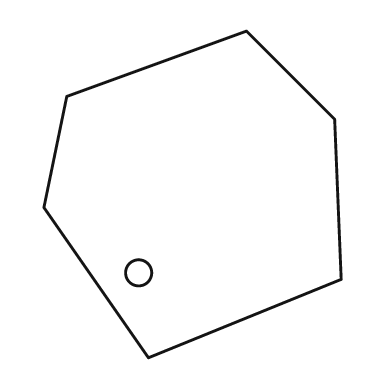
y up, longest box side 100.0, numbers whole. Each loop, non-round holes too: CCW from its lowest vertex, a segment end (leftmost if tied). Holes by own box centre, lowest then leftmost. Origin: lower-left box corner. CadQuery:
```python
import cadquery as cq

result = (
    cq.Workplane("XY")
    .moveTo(32.0, 0.0)
    .lineTo(91.0, 24.0)
    .lineTo(89.0, 73.0)
    .lineTo(62.0, 100.0)
    .lineTo(7.0, 80.0)
    .lineTo(0.0, 46.0)
    .close()
    .moveTo(29.0, 26.0)
    .circle(4.0)
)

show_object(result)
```